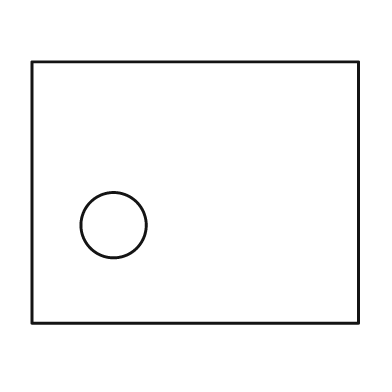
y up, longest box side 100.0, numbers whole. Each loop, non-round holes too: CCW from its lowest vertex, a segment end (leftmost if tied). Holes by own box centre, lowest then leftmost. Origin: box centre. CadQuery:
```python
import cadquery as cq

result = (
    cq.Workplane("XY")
    .moveTo(-50.0, -40.0)
    .lineTo(50.0, -40.0)
    .lineTo(50.0, 40.0)
    .lineTo(-50.0, 40.0)
    .close()
    .moveTo(-25.0, -10.0)
    .circle(10.0)
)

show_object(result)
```